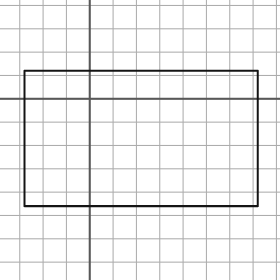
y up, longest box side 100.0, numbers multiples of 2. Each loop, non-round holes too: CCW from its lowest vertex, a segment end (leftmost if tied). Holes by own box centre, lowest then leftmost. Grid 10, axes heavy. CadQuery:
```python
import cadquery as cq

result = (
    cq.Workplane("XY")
    .moveTo(-28.0, -46.0)
    .lineTo(72.0, -46.0)
    .lineTo(72.0, 12.0)
    .lineTo(-28.0, 12.0)
    .close()
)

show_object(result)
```